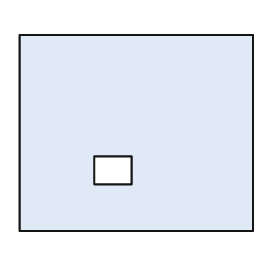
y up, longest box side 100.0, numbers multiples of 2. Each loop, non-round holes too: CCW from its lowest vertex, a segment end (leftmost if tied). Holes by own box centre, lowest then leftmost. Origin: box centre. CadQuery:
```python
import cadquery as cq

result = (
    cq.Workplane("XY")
    .moveTo(-50.0, -42.0)
    .lineTo(50.0, -42.0)
    .lineTo(50.0, 42.0)
    .lineTo(-50.0, 42.0)
    .close()
    .moveTo(-18.0, -22.0)
    .lineTo(-2.0, -22.0)
    .lineTo(-2.0, -10.0)
    .lineTo(-18.0, -10.0)
    .close()
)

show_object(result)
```